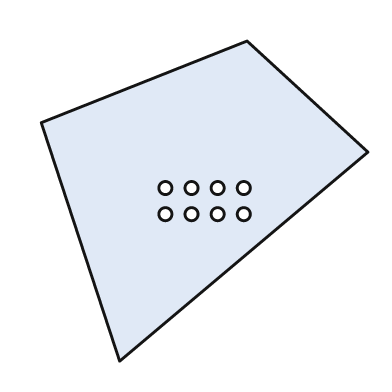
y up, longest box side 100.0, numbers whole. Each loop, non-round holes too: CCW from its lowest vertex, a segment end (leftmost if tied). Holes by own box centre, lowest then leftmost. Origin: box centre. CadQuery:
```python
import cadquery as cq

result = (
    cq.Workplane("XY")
    .moveTo(-26.0, -49.0)
    .lineTo(50.0, 15.0)
    .lineTo(13.0, 49.0)
    .lineTo(-50.0, 24.0)
    .close()
    .moveTo(-12.0, -4.0)
    .circle(2.0)
    .moveTo(-4.0, -4.0)
    .circle(2.0)
    .moveTo(4.0, -4.0)
    .circle(2.0)
    .moveTo(12.0, -4.0)
    .circle(2.0)
    .moveTo(-12.0, 4.0)
    .circle(2.0)
    .moveTo(-4.0, 4.0)
    .circle(2.0)
    .moveTo(4.0, 4.0)
    .circle(2.0)
    .moveTo(12.0, 4.0)
    .circle(2.0)
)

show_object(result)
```